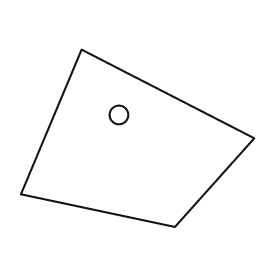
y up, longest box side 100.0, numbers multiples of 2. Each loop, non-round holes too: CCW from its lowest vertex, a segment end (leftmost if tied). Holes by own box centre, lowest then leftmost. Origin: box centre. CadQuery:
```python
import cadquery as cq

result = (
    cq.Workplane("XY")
    .moveTo(16.0, -38.0)
    .lineTo(50.0, 0.0)
    .lineTo(-24.0, 38.0)
    .lineTo(-50.0, -24.0)
    .close()
    .moveTo(-8.0, 10.0)
    .circle(4.0)
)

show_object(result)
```